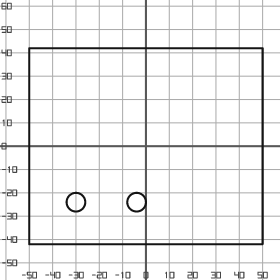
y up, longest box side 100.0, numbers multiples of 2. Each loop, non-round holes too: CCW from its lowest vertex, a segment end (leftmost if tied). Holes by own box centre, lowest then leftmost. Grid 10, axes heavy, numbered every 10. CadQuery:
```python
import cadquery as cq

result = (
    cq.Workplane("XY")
    .moveTo(-50.0, -42.0)
    .lineTo(50.0, -42.0)
    .lineTo(50.0, 42.0)
    .lineTo(-50.0, 42.0)
    .close()
    .moveTo(-30.0, -24.0)
    .circle(4.0)
    .moveTo(-4.0, -24.0)
    .circle(4.0)
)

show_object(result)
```